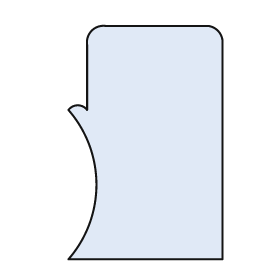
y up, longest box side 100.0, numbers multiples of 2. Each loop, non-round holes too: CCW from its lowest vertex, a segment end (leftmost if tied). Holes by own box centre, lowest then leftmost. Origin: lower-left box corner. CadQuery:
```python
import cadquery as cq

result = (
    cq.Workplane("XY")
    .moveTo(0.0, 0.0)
    .lineTo(66.0, 0.0)
    .lineTo(66.0, 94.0)
    .threePointArc((64.0, 98.0), (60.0, 100.0))
    .lineTo(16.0, 100.0)
    .threePointArc((10.0, 98.0), (8.0, 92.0))
    .lineTo(8.0, 64.0)
    .threePointArc((4.0, 66.0), (0.0, 64.0))
    .threePointArc((12.0, 32.0), (0.0, 0.0))
    .close()
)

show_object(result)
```